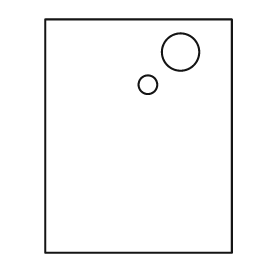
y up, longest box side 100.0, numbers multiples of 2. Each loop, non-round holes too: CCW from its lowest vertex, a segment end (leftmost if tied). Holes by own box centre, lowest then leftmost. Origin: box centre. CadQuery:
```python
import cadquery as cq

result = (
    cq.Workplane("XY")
    .moveTo(-40.0, -50.0)
    .lineTo(40.0, -50.0)
    .lineTo(40.0, 50.0)
    .lineTo(-40.0, 50.0)
    .close()
    .moveTo(4.0, 22.0)
    .circle(4.0)
    .moveTo(18.0, 36.0)
    .circle(8.0)
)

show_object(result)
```